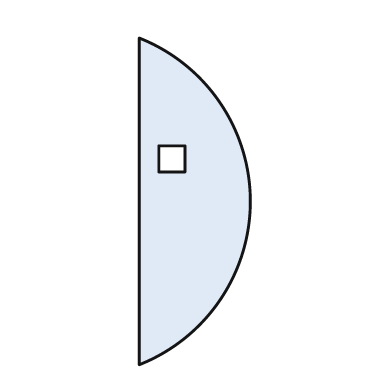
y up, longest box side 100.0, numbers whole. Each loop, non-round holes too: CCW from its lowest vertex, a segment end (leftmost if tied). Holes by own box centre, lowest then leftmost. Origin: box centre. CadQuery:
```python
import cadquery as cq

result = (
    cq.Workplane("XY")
    .moveTo(-17.0, -50.0)
    .threePointArc((17.0, 0.0), (-17.0, 50.0))
    .close()
    .moveTo(-11.0, 9.0)
    .lineTo(-3.0, 9.0)
    .lineTo(-3.0, 17.0)
    .lineTo(-11.0, 17.0)
    .close()
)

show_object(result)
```